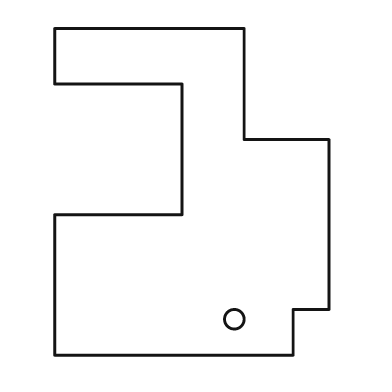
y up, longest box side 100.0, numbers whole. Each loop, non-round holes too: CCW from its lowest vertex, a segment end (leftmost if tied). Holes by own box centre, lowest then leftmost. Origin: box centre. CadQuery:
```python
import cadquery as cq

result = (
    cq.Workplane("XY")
    .moveTo(-42.0, -50.0)
    .lineTo(31.0, -50.0)
    .lineTo(31.0, -36.0)
    .lineTo(42.0, -36.0)
    .lineTo(42.0, 16.0)
    .lineTo(16.0, 16.0)
    .lineTo(16.0, 50.0)
    .lineTo(-42.0, 50.0)
    .lineTo(-42.0, 33.0)
    .lineTo(-3.0, 33.0)
    .lineTo(-3.0, -7.0)
    .lineTo(-42.0, -7.0)
    .close()
    .moveTo(13.0, -39.0)
    .circle(3.0)
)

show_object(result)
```